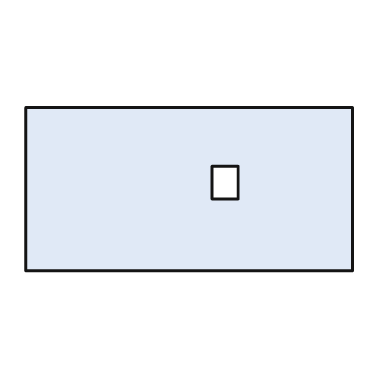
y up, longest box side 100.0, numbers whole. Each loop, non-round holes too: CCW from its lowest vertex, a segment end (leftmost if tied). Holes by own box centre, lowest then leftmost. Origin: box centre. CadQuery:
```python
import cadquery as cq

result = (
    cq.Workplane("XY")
    .moveTo(-50.0, -25.0)
    .lineTo(50.0, -25.0)
    .lineTo(50.0, 25.0)
    .lineTo(-50.0, 25.0)
    .close()
    .moveTo(7.0, -3.0)
    .lineTo(15.0, -3.0)
    .lineTo(15.0, 7.0)
    .lineTo(7.0, 7.0)
    .close()
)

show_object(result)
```